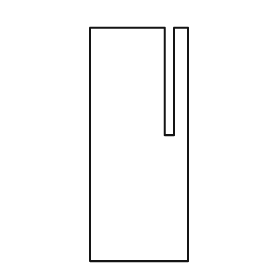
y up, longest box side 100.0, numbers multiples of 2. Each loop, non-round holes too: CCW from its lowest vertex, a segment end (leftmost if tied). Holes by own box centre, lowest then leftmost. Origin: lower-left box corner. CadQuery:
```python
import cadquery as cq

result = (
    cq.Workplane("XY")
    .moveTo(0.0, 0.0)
    .lineTo(42.0, 0.0)
    .lineTo(42.0, 100.0)
    .lineTo(36.0, 100.0)
    .lineTo(36.0, 54.0)
    .lineTo(32.0, 54.0)
    .lineTo(32.0, 100.0)
    .lineTo(0.0, 100.0)
    .close()
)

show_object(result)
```